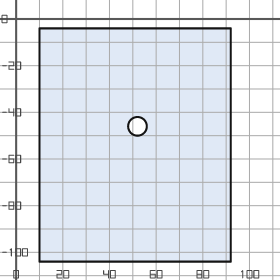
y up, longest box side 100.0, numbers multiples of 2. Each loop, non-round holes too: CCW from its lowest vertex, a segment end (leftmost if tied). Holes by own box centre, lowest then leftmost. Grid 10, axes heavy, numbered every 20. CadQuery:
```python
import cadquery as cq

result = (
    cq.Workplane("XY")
    .moveTo(10.0, -104.0)
    .lineTo(92.0, -104.0)
    .lineTo(92.0, -4.0)
    .lineTo(10.0, -4.0)
    .close()
    .moveTo(52.0, -46.0)
    .circle(4.0)
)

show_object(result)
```